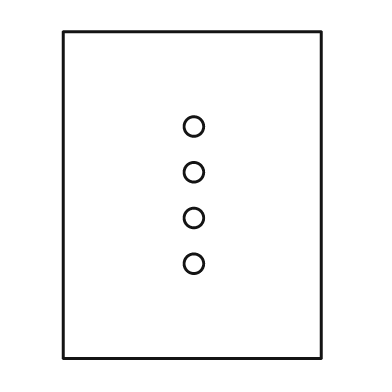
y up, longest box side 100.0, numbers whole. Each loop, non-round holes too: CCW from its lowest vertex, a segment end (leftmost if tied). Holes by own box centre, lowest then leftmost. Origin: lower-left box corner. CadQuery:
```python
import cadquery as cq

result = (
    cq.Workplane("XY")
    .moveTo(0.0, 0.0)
    .lineTo(79.0, 0.0)
    .lineTo(79.0, 100.0)
    .lineTo(0.0, 100.0)
    .close()
    .moveTo(40.0, 29.0)
    .circle(3.0)
    .moveTo(40.0, 43.0)
    .circle(3.0)
    .moveTo(40.0, 57.0)
    .circle(3.0)
    .moveTo(40.0, 71.0)
    .circle(3.0)
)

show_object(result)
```